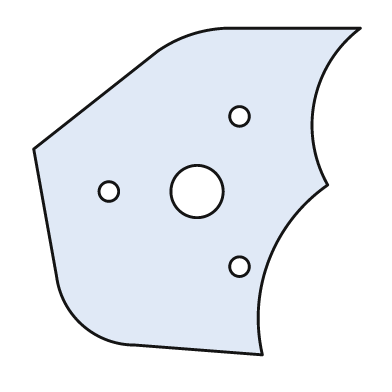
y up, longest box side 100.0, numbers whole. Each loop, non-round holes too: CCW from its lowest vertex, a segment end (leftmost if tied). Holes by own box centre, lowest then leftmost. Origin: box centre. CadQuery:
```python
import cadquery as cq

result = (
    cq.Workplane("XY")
    .moveTo(20.0, -50.0)
    .threePointArc((22.0, -21.0), (40.0, 2.0))
    .threePointArc((36.0, 28.0), (50.0, 50.0))
    .lineTo(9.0, 50.0)
    .threePointArc((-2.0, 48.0), (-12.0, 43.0))
    .lineTo(-50.0, 13.0)
    .lineTo(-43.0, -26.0)
    .threePointArc((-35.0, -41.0), (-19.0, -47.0))
    .close()
    .moveTo(13.0, -23.0)
    .circle(3.0)
    .moveTo(-27.0, 0.0)
    .circle(3.0)
    .moveTo(0.0, 0.0)
    .circle(8.0)
    .moveTo(13.0, 23.0)
    .circle(3.0)
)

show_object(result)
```